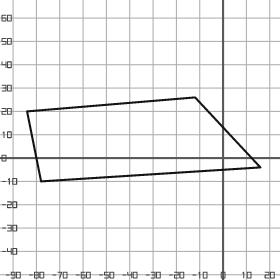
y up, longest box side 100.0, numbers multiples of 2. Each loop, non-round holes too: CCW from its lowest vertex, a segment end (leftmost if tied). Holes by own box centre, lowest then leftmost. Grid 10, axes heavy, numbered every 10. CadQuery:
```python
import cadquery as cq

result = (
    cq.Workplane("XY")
    .moveTo(-78.0, -10.0)
    .lineTo(16.0, -4.0)
    .lineTo(-12.0, 26.0)
    .lineTo(-84.0, 20.0)
    .close()
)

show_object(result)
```